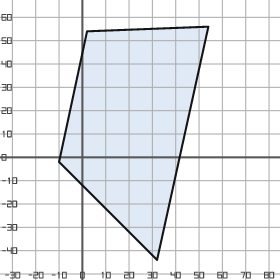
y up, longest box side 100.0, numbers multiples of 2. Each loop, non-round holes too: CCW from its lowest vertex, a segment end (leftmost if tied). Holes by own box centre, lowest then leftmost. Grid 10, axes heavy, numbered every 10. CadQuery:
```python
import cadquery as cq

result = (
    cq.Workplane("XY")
    .moveTo(32.0, -44.0)
    .lineTo(54.0, 56.0)
    .lineTo(2.0, 54.0)
    .lineTo(-10.0, -2.0)
    .close()
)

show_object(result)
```